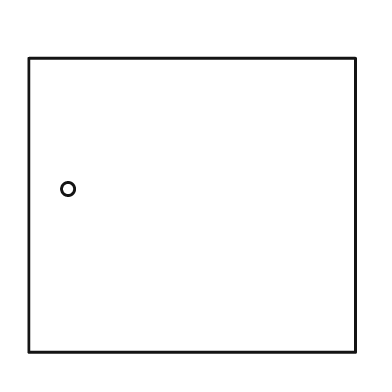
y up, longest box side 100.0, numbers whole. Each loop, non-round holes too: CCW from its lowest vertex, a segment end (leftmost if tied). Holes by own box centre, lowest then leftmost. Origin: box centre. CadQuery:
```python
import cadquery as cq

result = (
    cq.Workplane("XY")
    .moveTo(-50.0, -45.0)
    .lineTo(50.0, -45.0)
    .lineTo(50.0, 45.0)
    .lineTo(-50.0, 45.0)
    .close()
    .moveTo(-38.0, 5.0)
    .circle(2.0)
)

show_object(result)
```